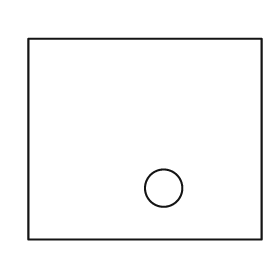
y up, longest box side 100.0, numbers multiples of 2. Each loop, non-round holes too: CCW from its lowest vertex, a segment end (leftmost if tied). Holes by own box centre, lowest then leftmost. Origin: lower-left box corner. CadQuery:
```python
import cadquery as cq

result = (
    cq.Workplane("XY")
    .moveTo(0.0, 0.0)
    .lineTo(100.0, 0.0)
    .lineTo(100.0, 86.0)
    .lineTo(0.0, 86.0)
    .close()
    .moveTo(58.0, 22.0)
    .circle(8.0)
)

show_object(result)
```